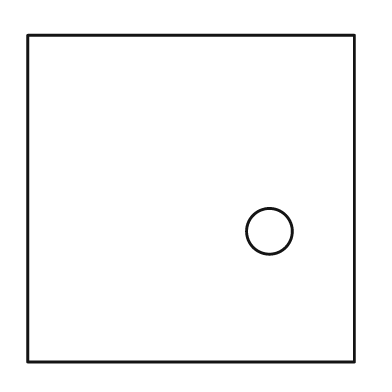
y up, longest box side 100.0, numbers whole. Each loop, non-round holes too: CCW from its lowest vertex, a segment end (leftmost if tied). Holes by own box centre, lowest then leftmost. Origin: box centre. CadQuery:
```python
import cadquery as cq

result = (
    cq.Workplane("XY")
    .moveTo(-50.0, -50.0)
    .lineTo(50.0, -50.0)
    .lineTo(50.0, 50.0)
    .lineTo(-50.0, 50.0)
    .close()
    .moveTo(24.0, -10.0)
    .circle(7.0)
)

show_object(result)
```